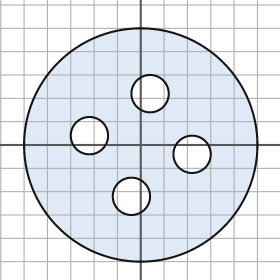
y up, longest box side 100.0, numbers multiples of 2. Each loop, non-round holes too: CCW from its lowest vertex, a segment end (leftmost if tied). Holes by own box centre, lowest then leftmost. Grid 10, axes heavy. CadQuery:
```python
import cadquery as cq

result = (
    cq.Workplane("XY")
    .moveTo(0.0, 0.0)
    .circle(50.0)
    .moveTo(-4.0, -22.0)
    .circle(8.0)
    .moveTo(22.0, -4.0)
    .circle(8.0)
    .moveTo(-22.0, 4.0)
    .circle(8.0)
    .moveTo(4.0, 22.0)
    .circle(8.0)
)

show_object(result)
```